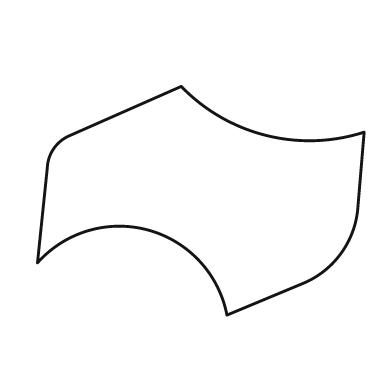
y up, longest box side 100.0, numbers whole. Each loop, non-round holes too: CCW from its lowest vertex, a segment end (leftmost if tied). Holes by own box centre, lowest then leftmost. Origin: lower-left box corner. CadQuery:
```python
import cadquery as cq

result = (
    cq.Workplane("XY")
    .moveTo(58.0, 0.0)
    .lineTo(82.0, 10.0)
    .threePointArc((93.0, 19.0), (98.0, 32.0))
    .lineTo(100.0, 56.0)
    .threePointArc((70.0, 55.0), (44.0, 70.0))
    .lineTo(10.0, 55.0)
    .threePointArc((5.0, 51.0), (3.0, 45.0))
    .lineTo(0.0, 16.0)
    .threePointArc((34.0, 26.0), (58.0, 0.0))
    .close()
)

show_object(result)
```